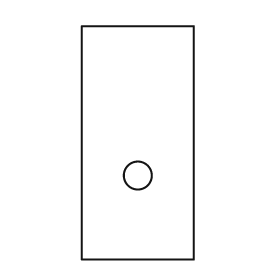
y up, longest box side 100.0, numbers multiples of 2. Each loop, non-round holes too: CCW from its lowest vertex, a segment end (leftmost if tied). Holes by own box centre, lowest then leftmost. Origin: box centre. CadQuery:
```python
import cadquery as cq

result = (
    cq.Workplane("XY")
    .moveTo(-24.0, -50.0)
    .lineTo(24.0, -50.0)
    .lineTo(24.0, 50.0)
    .lineTo(-24.0, 50.0)
    .close()
    .moveTo(0.0, -14.0)
    .circle(6.0)
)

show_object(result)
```